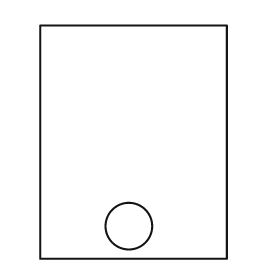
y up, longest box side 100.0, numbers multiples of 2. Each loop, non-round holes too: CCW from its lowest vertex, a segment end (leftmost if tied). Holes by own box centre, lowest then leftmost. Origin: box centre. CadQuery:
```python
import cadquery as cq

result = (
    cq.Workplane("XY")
    .moveTo(-40.0, -50.0)
    .lineTo(40.0, -50.0)
    .lineTo(40.0, 50.0)
    .lineTo(-40.0, 50.0)
    .close()
    .moveTo(-2.0, -36.0)
    .circle(10.0)
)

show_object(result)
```